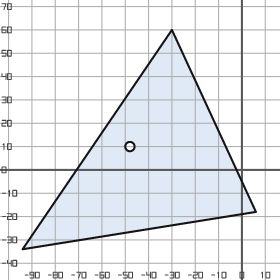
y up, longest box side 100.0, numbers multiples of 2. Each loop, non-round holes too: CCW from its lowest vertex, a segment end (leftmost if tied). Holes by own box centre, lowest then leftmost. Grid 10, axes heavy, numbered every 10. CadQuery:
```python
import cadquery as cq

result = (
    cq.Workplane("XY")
    .moveTo(-94.0, -34.0)
    .lineTo(6.0, -18.0)
    .lineTo(-30.0, 60.0)
    .close()
    .moveTo(-48.0, 10.0)
    .circle(2.0)
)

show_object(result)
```